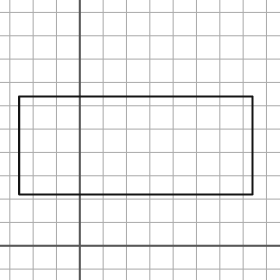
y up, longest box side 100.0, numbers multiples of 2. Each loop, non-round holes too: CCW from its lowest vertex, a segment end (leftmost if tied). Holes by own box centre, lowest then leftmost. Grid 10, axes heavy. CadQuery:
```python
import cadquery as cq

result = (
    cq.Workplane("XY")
    .moveTo(-26.0, 22.0)
    .lineTo(74.0, 22.0)
    .lineTo(74.0, 64.0)
    .lineTo(-26.0, 64.0)
    .close()
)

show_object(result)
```